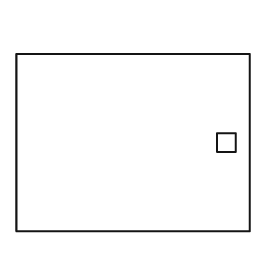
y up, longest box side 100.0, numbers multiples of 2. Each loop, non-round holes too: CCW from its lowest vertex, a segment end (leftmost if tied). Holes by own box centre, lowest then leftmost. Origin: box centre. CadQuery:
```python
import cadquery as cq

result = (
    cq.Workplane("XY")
    .moveTo(-50.0, -38.0)
    .lineTo(50.0, -38.0)
    .lineTo(50.0, 38.0)
    .lineTo(-50.0, 38.0)
    .close()
    .moveTo(36.0, -4.0)
    .lineTo(44.0, -4.0)
    .lineTo(44.0, 4.0)
    .lineTo(36.0, 4.0)
    .close()
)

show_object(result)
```